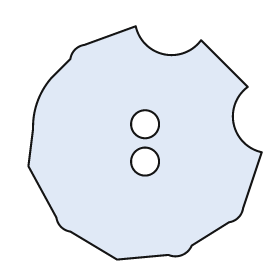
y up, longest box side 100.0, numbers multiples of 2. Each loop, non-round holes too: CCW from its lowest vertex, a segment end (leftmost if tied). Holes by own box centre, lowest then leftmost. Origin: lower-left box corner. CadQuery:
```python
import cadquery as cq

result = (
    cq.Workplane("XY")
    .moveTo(38.0, 0.0)
    .lineTo(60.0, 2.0)
    .threePointArc((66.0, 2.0), (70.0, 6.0))
    .lineTo(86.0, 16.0)
    .threePointArc((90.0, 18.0), (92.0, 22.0))
    .lineTo(100.0, 46.0)
    .threePointArc((88.0, 58.0), (94.0, 74.0))
    .lineTo(74.0, 94.0)
    .threePointArc((58.0, 88.0), (46.0, 100.0))
    .lineTo(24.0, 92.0)
    .threePointArc((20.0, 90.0), (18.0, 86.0))
    .lineTo(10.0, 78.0)
    .threePointArc((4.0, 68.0), (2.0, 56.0))
    .lineTo(0.0, 40.0)
    .lineTo(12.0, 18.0)
    .threePointArc((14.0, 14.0), (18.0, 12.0))
    .close()
    .moveTo(50.0, 42.0)
    .circle(6.0)
    .moveTo(50.0, 58.0)
    .circle(6.0)
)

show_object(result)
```